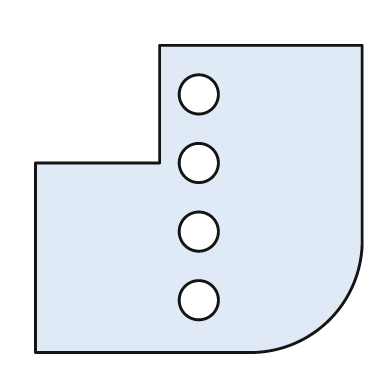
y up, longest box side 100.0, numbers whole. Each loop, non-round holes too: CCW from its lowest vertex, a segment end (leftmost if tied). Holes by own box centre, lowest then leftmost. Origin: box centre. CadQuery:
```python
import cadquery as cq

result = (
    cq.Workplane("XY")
    .moveTo(-50.0, -47.0)
    .lineTo(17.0, -47.0)
    .threePointArc((40.0, -37.0), (50.0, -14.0))
    .lineTo(50.0, 47.0)
    .lineTo(-12.0, 47.0)
    .lineTo(-12.0, 11.0)
    .lineTo(-50.0, 11.0)
    .close()
    .moveTo(0.0, -31.0)
    .circle(6.0)
    .moveTo(0.0, -10.0)
    .circle(6.0)
    .moveTo(0.0, 11.0)
    .circle(6.0)
    .moveTo(0.0, 32.0)
    .circle(6.0)
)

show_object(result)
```